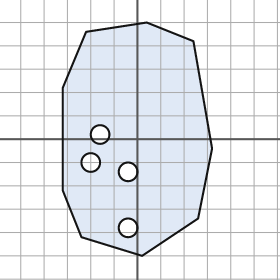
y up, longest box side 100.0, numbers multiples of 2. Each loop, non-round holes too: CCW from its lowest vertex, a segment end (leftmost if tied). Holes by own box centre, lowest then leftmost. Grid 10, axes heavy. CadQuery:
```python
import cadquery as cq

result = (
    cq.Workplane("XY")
    .moveTo(2.0, -50.0)
    .lineTo(26.0, -34.0)
    .lineTo(32.0, -4.0)
    .lineTo(24.0, 42.0)
    .lineTo(4.0, 50.0)
    .lineTo(-22.0, 46.0)
    .lineTo(-32.0, 22.0)
    .lineTo(-32.0, -22.0)
    .lineTo(-24.0, -42.0)
    .close()
    .moveTo(-4.0, -38.0)
    .circle(4.0)
    .moveTo(-4.0, -14.0)
    .circle(4.0)
    .moveTo(-20.0, -10.0)
    .circle(4.0)
    .moveTo(-16.0, 2.0)
    .circle(4.0)
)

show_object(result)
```